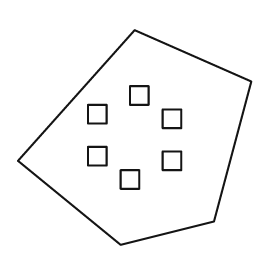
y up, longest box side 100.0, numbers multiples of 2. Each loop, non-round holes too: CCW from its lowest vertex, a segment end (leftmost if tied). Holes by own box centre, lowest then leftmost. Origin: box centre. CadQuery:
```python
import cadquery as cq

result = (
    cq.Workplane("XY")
    .moveTo(-6.0, -46.0)
    .lineTo(34.0, -36.0)
    .lineTo(50.0, 24.0)
    .lineTo(0.0, 46.0)
    .lineTo(-50.0, -10.0)
    .close()
    .moveTo(-6.0, -22.0)
    .lineTo(2.0, -22.0)
    .lineTo(2.0, -14.0)
    .lineTo(-6.0, -14.0)
    .close()
    .moveTo(12.0, -14.0)
    .lineTo(20.0, -14.0)
    .lineTo(20.0, -6.0)
    .lineTo(12.0, -6.0)
    .close()
    .moveTo(-20.0, -12.0)
    .lineTo(-12.0, -12.0)
    .lineTo(-12.0, -4.0)
    .lineTo(-20.0, -4.0)
    .close()
    .moveTo(12.0, 4.0)
    .lineTo(20.0, 4.0)
    .lineTo(20.0, 12.0)
    .lineTo(12.0, 12.0)
    .close()
    .moveTo(-20.0, 6.0)
    .lineTo(-12.0, 6.0)
    .lineTo(-12.0, 14.0)
    .lineTo(-20.0, 14.0)
    .close()
    .moveTo(-2.0, 14.0)
    .lineTo(6.0, 14.0)
    .lineTo(6.0, 22.0)
    .lineTo(-2.0, 22.0)
    .close()
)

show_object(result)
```